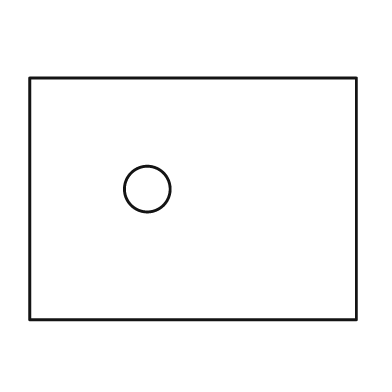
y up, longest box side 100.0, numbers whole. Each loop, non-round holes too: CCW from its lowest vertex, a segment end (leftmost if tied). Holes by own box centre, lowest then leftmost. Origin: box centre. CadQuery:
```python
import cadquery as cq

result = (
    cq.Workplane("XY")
    .moveTo(-50.0, -37.0)
    .lineTo(50.0, -37.0)
    .lineTo(50.0, 37.0)
    .lineTo(-50.0, 37.0)
    .close()
    .moveTo(-14.0, 3.0)
    .circle(7.0)
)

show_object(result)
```